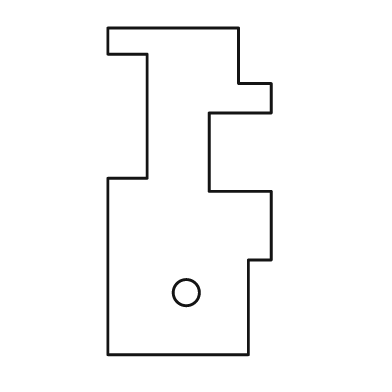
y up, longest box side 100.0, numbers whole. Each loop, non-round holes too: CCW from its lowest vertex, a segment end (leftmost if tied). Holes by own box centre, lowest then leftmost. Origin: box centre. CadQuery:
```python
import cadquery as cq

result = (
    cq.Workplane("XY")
    .moveTo(-25.0, -50.0)
    .lineTo(18.0, -50.0)
    .lineTo(18.0, -21.0)
    .lineTo(25.0, -21.0)
    .lineTo(25.0, 0.0)
    .lineTo(6.0, 0.0)
    .lineTo(6.0, 24.0)
    .lineTo(25.0, 24.0)
    .lineTo(25.0, 33.0)
    .lineTo(15.0, 33.0)
    .lineTo(15.0, 50.0)
    .lineTo(-25.0, 50.0)
    .lineTo(-25.0, 42.0)
    .lineTo(-13.0, 42.0)
    .lineTo(-13.0, 4.0)
    .lineTo(-25.0, 4.0)
    .close()
    .moveTo(-1.0, -31.0)
    .circle(4.0)
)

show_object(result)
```